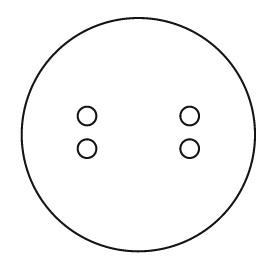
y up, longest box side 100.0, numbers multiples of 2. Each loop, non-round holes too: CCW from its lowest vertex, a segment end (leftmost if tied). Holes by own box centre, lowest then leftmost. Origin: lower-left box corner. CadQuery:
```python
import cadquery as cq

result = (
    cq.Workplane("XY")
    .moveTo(50.0, 50.0)
    .circle(50.0)
    .moveTo(28.0, 44.0)
    .circle(4.0)
    .moveTo(72.0, 44.0)
    .circle(4.0)
    .moveTo(28.0, 58.0)
    .circle(4.0)
    .moveTo(72.0, 58.0)
    .circle(4.0)
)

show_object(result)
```